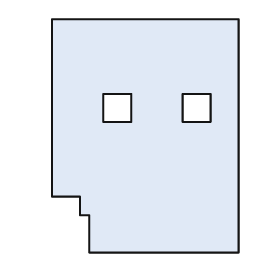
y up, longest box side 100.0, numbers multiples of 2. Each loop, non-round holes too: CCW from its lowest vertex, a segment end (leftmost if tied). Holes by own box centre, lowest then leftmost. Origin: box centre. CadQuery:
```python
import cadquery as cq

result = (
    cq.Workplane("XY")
    .moveTo(-24.0, -50.0)
    .lineTo(40.0, -50.0)
    .lineTo(40.0, 50.0)
    .lineTo(-40.0, 50.0)
    .lineTo(-40.0, -26.0)
    .lineTo(-28.0, -26.0)
    .lineTo(-28.0, -34.0)
    .lineTo(-24.0, -34.0)
    .close()
    .moveTo(-18.0, 6.0)
    .lineTo(-6.0, 6.0)
    .lineTo(-6.0, 18.0)
    .lineTo(-18.0, 18.0)
    .close()
    .moveTo(16.0, 6.0)
    .lineTo(28.0, 6.0)
    .lineTo(28.0, 18.0)
    .lineTo(16.0, 18.0)
    .close()
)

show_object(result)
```